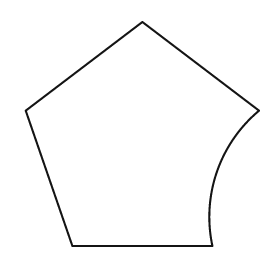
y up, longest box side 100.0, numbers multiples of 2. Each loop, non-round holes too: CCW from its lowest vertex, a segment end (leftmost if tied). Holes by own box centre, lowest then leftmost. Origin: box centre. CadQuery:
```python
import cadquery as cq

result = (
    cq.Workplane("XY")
    .moveTo(-30.0, -48.0)
    .lineTo(30.0, -48.0)
    .threePointArc((32.0, -16.0), (50.0, 10.0))
    .lineTo(0.0, 48.0)
    .lineTo(-50.0, 10.0)
    .close()
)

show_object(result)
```